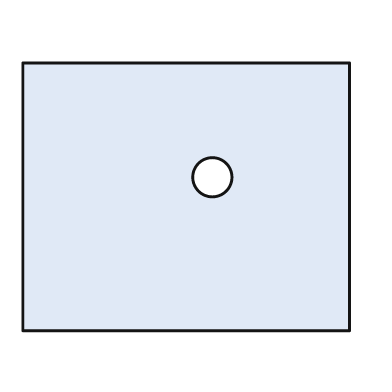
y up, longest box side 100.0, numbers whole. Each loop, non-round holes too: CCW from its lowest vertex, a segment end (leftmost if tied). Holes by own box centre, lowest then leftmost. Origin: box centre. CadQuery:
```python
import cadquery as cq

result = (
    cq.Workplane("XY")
    .moveTo(-50.0, -41.0)
    .lineTo(50.0, -41.0)
    .lineTo(50.0, 41.0)
    .lineTo(-50.0, 41.0)
    .close()
    .moveTo(8.0, 6.0)
    .circle(6.0)
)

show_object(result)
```